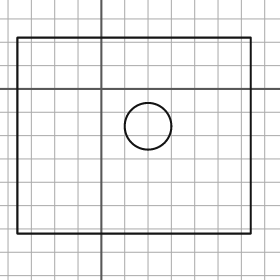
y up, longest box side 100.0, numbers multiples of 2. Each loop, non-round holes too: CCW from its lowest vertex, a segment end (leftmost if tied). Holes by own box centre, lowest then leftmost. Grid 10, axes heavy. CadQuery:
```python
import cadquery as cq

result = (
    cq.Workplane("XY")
    .moveTo(-36.0, -62.0)
    .lineTo(64.0, -62.0)
    .lineTo(64.0, 22.0)
    .lineTo(-36.0, 22.0)
    .close()
    .moveTo(20.0, -16.0)
    .circle(10.0)
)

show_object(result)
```